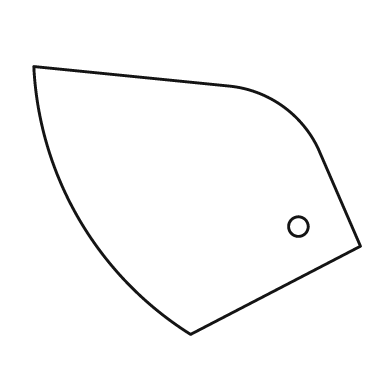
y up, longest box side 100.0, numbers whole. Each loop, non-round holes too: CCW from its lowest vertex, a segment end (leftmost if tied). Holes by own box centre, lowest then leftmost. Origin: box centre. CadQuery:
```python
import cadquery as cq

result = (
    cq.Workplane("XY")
    .moveTo(-2.0, -41.0)
    .lineTo(50.0, -14.0)
    .lineTo(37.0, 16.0)
    .threePointArc((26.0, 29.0), (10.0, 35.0))
    .lineTo(-50.0, 41.0)
    .threePointArc((-36.0, -6.0), (-2.0, -41.0))
    .close()
    .moveTo(31.0, -8.0)
    .circle(3.0)
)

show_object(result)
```